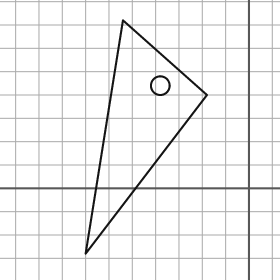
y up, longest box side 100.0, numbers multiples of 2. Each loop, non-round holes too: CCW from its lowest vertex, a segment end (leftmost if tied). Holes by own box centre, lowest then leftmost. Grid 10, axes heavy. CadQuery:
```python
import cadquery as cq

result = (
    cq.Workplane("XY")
    .moveTo(-70.0, -28.0)
    .lineTo(-18.0, 40.0)
    .lineTo(-54.0, 72.0)
    .close()
    .moveTo(-38.0, 44.0)
    .circle(4.0)
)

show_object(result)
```